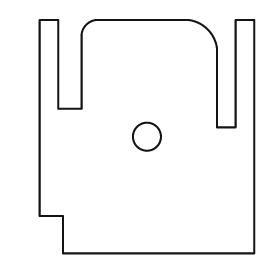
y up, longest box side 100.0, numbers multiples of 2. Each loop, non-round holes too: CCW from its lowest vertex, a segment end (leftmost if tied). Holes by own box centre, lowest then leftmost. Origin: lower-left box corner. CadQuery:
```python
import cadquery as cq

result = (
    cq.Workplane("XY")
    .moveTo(10.0, 0.0)
    .lineTo(92.0, 0.0)
    .lineTo(92.0, 100.0)
    .lineTo(84.0, 100.0)
    .lineTo(84.0, 54.0)
    .lineTo(76.0, 54.0)
    .lineTo(76.0, 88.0)
    .threePointArc((72.0, 96.0), (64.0, 100.0))
    .lineTo(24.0, 100.0)
    .threePointArc((20.0, 98.0), (18.0, 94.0))
    .lineTo(18.0, 62.0)
    .lineTo(8.0, 62.0)
    .lineTo(8.0, 100.0)
    .lineTo(0.0, 100.0)
    .lineTo(0.0, 16.0)
    .lineTo(10.0, 16.0)
    .close()
    .moveTo(46.0, 50.0)
    .circle(6.0)
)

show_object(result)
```